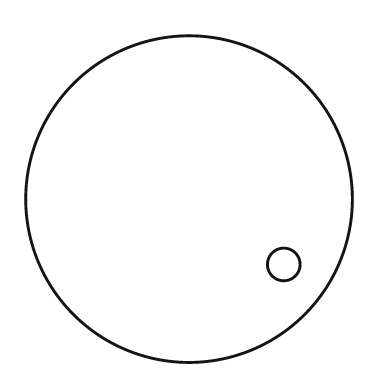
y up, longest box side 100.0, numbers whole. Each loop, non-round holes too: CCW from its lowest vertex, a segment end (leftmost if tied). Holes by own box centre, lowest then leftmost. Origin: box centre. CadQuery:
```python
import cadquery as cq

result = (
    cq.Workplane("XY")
    .moveTo(0.0, 0.0)
    .circle(50.0)
    .moveTo(29.0, -20.0)
    .circle(5.0)
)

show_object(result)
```